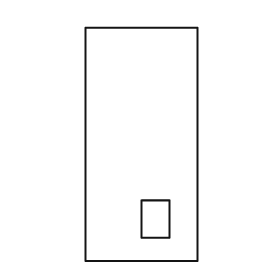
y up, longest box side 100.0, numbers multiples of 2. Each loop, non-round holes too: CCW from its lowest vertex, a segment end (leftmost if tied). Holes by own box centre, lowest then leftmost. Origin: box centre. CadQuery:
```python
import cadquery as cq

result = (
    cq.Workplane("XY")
    .moveTo(-24.0, -50.0)
    .lineTo(24.0, -50.0)
    .lineTo(24.0, 50.0)
    .lineTo(-24.0, 50.0)
    .close()
    .moveTo(0.0, -40.0)
    .lineTo(12.0, -40.0)
    .lineTo(12.0, -24.0)
    .lineTo(0.0, -24.0)
    .close()
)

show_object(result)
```